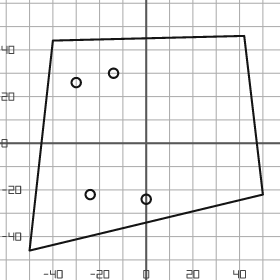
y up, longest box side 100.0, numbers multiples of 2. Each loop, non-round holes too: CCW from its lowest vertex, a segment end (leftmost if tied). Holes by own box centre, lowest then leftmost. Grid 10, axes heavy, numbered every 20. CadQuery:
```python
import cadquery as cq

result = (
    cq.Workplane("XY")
    .moveTo(-50.0, -46.0)
    .lineTo(50.0, -22.0)
    .lineTo(42.0, 46.0)
    .lineTo(-40.0, 44.0)
    .close()
    .moveTo(0.0, -24.0)
    .circle(2.0)
    .moveTo(-24.0, -22.0)
    .circle(2.0)
    .moveTo(-30.0, 26.0)
    .circle(2.0)
    .moveTo(-14.0, 30.0)
    .circle(2.0)
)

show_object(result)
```